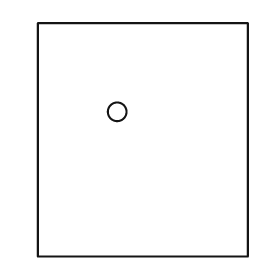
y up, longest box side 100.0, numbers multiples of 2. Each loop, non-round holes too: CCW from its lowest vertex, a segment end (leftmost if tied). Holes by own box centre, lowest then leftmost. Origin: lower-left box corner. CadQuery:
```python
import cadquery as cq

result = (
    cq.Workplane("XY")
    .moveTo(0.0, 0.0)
    .lineTo(90.0, 0.0)
    .lineTo(90.0, 100.0)
    .lineTo(0.0, 100.0)
    .close()
    .moveTo(34.0, 62.0)
    .circle(4.0)
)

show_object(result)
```